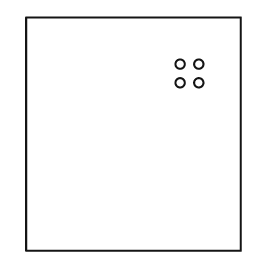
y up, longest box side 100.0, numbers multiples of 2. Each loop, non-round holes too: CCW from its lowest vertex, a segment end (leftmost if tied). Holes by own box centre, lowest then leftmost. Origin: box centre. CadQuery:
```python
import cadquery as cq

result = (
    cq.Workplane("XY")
    .moveTo(-46.0, -50.0)
    .lineTo(46.0, -50.0)
    .lineTo(46.0, 50.0)
    .lineTo(-46.0, 50.0)
    .close()
    .moveTo(20.0, 22.0)
    .circle(2.0)
    .moveTo(28.0, 22.0)
    .circle(2.0)
    .moveTo(20.0, 30.0)
    .circle(2.0)
    .moveTo(28.0, 30.0)
    .circle(2.0)
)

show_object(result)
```